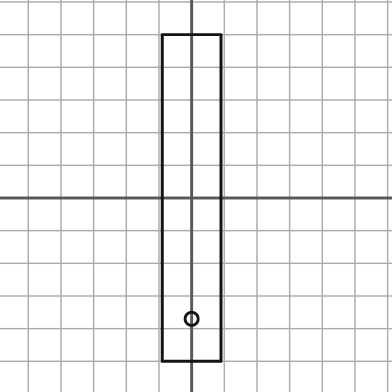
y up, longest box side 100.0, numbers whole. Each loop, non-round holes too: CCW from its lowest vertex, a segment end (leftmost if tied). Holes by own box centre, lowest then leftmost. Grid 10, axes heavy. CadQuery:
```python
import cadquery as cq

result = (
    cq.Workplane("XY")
    .moveTo(-9.0, -50.0)
    .lineTo(9.0, -50.0)
    .lineTo(9.0, 50.0)
    .lineTo(-9.0, 50.0)
    .close()
    .moveTo(0.0, -37.0)
    .circle(2.0)
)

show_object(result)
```